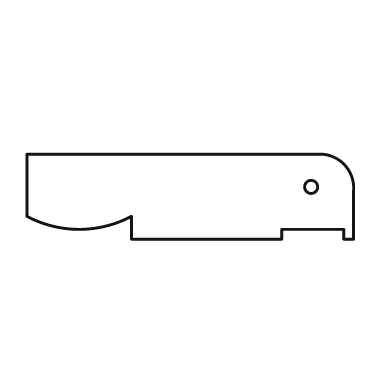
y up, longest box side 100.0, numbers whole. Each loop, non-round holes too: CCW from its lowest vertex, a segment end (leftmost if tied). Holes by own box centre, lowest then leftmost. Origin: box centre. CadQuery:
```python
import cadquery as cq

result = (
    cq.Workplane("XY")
    .moveTo(-18.0, -13.0)
    .lineTo(28.0, -13.0)
    .lineTo(28.0, -10.0)
    .lineTo(47.0, -10.0)
    .lineTo(47.0, -13.0)
    .lineTo(50.0, -13.0)
    .lineTo(50.0, 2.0)
    .threePointArc((47.0, 10.0), (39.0, 13.0))
    .lineTo(-50.0, 13.0)
    .lineTo(-50.0, -6.0)
    .threePointArc((-34.0, -10.0), (-18.0, -6.0))
    .close()
    .moveTo(37.0, 3.0)
    .circle(2.0)
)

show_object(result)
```